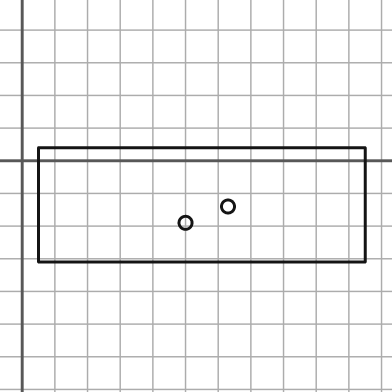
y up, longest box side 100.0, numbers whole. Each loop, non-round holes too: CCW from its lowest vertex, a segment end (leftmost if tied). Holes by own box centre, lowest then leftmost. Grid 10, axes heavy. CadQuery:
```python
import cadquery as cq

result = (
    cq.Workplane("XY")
    .moveTo(5.0, -31.0)
    .lineTo(105.0, -31.0)
    .lineTo(105.0, 4.0)
    .lineTo(5.0, 4.0)
    .close()
    .moveTo(50.0, -19.0)
    .circle(2.0)
    .moveTo(63.0, -14.0)
    .circle(2.0)
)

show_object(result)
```